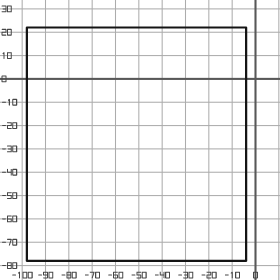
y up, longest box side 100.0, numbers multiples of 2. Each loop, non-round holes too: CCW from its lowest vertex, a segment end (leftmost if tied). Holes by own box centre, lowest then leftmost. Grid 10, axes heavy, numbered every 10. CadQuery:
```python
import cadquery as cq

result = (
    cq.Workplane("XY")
    .moveTo(-98.0, -78.0)
    .lineTo(-4.0, -78.0)
    .lineTo(-4.0, 22.0)
    .lineTo(-98.0, 22.0)
    .close()
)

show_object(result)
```